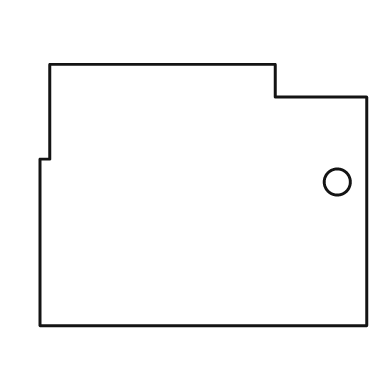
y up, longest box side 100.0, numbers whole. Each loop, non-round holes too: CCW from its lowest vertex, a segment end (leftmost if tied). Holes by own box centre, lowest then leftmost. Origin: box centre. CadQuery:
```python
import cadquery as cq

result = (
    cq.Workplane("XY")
    .moveTo(-50.0, -40.0)
    .lineTo(50.0, -40.0)
    .lineTo(50.0, 30.0)
    .lineTo(22.0, 30.0)
    .lineTo(22.0, 40.0)
    .lineTo(-47.0, 40.0)
    .lineTo(-47.0, 11.0)
    .lineTo(-50.0, 11.0)
    .close()
    .moveTo(41.0, 4.0)
    .circle(4.0)
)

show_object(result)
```